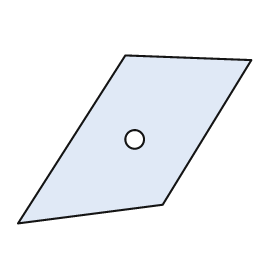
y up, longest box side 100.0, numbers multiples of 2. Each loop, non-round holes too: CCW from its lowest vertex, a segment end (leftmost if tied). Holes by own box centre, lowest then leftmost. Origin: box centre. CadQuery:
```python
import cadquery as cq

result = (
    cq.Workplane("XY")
    .moveTo(-50.0, -36.0)
    .lineTo(12.0, -28.0)
    .lineTo(50.0, 34.0)
    .lineTo(-4.0, 36.0)
    .close()
    .moveTo(0.0, 0.0)
    .circle(4.0)
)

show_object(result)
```